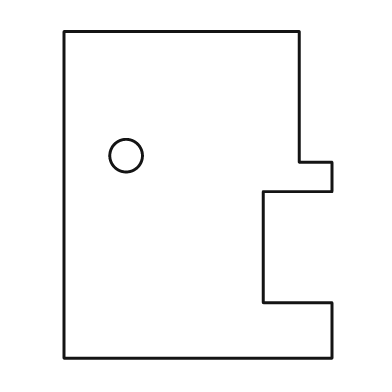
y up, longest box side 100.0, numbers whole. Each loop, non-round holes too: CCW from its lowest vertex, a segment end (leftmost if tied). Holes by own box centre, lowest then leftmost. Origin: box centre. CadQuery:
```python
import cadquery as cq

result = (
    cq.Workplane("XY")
    .moveTo(-41.0, -50.0)
    .lineTo(41.0, -50.0)
    .lineTo(41.0, -33.0)
    .lineTo(20.0, -33.0)
    .lineTo(20.0, 1.0)
    .lineTo(41.0, 1.0)
    .lineTo(41.0, 10.0)
    .lineTo(31.0, 10.0)
    .lineTo(31.0, 50.0)
    .lineTo(-41.0, 50.0)
    .close()
    .moveTo(-22.0, 12.0)
    .circle(5.0)
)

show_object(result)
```